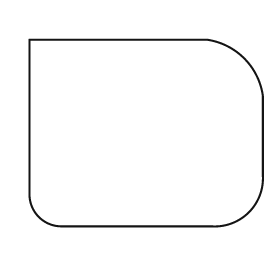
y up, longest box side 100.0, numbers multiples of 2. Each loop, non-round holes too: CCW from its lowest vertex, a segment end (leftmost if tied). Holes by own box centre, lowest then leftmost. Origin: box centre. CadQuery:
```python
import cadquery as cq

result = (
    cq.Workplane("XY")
    .moveTo(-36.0, -40.0)
    .lineTo(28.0, -40.0)
    .threePointArc((44.0, -34.0), (50.0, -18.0))
    .lineTo(50.0, 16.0)
    .threePointArc((42.0, 32.0), (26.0, 40.0))
    .lineTo(-50.0, 40.0)
    .lineTo(-50.0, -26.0)
    .threePointArc((-46.0, -36.0), (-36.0, -40.0))
    .close()
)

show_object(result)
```